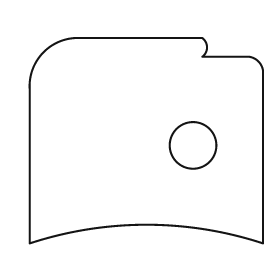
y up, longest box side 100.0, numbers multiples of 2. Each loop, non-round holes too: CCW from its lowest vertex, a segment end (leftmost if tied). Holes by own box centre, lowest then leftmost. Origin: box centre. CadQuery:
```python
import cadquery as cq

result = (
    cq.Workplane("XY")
    .moveTo(-50.0, -44.0)
    .threePointArc((0.0, -36.0), (50.0, -44.0))
    .lineTo(50.0, 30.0)
    .threePointArc((48.0, 34.0), (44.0, 36.0))
    .lineTo(24.0, 36.0)
    .threePointArc((26.0, 40.0), (24.0, 44.0))
    .lineTo(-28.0, 44.0)
    .threePointArc((-44.0, 38.0), (-50.0, 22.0))
    .close()
    .moveTo(20.0, -2.0)
    .circle(10.0)
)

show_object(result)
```